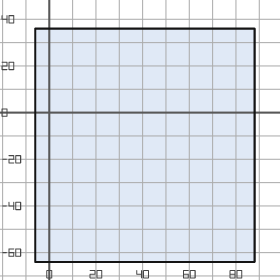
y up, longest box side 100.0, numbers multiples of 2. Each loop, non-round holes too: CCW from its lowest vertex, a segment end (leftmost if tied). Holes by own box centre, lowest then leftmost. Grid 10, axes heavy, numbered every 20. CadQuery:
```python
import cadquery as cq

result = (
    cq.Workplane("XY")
    .moveTo(-6.0, -64.0)
    .lineTo(88.0, -64.0)
    .lineTo(88.0, 36.0)
    .lineTo(-6.0, 36.0)
    .close()
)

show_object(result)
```